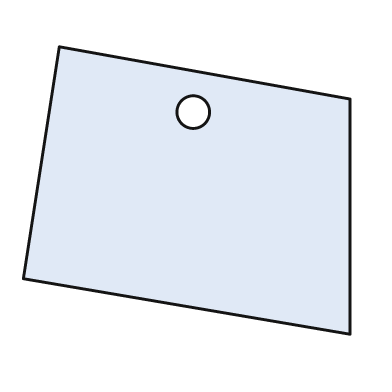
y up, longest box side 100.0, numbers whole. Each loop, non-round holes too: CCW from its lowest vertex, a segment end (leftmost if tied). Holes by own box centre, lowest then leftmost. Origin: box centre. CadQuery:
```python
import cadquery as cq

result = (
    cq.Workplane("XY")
    .moveTo(50.0, -44.0)
    .lineTo(50.0, 28.0)
    .lineTo(-39.0, 44.0)
    .lineTo(-50.0, -27.0)
    .close()
    .moveTo(2.0, 24.0)
    .circle(5.0)
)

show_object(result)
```